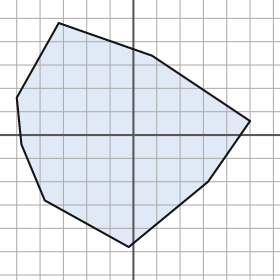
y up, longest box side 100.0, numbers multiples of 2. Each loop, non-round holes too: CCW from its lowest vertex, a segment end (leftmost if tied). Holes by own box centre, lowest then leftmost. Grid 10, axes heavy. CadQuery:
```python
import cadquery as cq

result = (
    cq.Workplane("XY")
    .moveTo(-2.0, -48.0)
    .lineTo(32.0, -20.0)
    .lineTo(50.0, 6.0)
    .lineTo(8.0, 34.0)
    .lineTo(-32.0, 48.0)
    .lineTo(-50.0, 16.0)
    .lineTo(-48.0, -4.0)
    .lineTo(-38.0, -28.0)
    .close()
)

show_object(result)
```